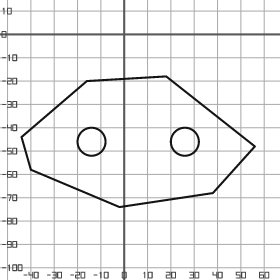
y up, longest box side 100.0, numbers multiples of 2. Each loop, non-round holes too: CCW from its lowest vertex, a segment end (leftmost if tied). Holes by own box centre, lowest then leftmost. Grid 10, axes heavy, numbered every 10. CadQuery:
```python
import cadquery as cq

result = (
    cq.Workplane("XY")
    .moveTo(-2.0, -74.0)
    .lineTo(38.0, -68.0)
    .lineTo(56.0, -48.0)
    .lineTo(18.0, -18.0)
    .lineTo(-16.0, -20.0)
    .lineTo(-44.0, -44.0)
    .lineTo(-40.0, -58.0)
    .close()
    .moveTo(-14.0, -46.0)
    .circle(6.0)
    .moveTo(26.0, -46.0)
    .circle(6.0)
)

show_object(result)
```